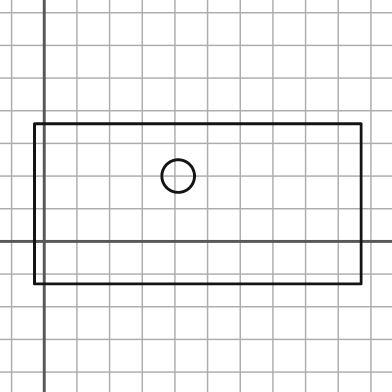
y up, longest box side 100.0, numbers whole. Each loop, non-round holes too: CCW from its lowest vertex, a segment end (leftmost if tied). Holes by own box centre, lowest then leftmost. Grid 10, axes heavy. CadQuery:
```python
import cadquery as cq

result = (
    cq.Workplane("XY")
    .moveTo(-3.0, -13.0)
    .lineTo(97.0, -13.0)
    .lineTo(97.0, 36.0)
    .lineTo(-3.0, 36.0)
    .close()
    .moveTo(41.0, 20.0)
    .circle(5.0)
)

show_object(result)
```